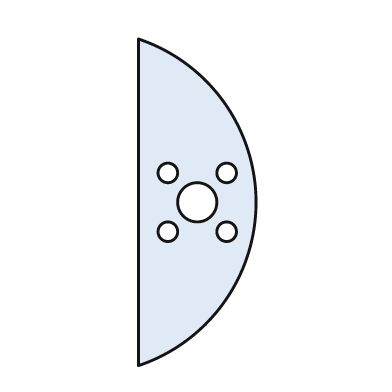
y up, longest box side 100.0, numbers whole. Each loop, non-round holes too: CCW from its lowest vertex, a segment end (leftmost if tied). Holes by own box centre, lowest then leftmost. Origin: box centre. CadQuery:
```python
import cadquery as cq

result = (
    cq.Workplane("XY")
    .moveTo(-18.0, -50.0)
    .threePointArc((18.0, 0.0), (-18.0, 50.0))
    .close()
    .moveTo(-9.0, -9.0)
    .circle(3.0)
    .moveTo(9.0, -9.0)
    .circle(3.0)
    .moveTo(0.0, 0.0)
    .circle(6.0)
    .moveTo(-9.0, 9.0)
    .circle(3.0)
    .moveTo(9.0, 9.0)
    .circle(3.0)
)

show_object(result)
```